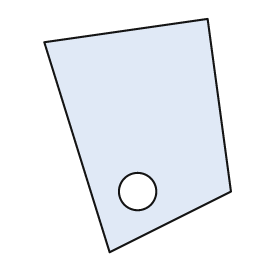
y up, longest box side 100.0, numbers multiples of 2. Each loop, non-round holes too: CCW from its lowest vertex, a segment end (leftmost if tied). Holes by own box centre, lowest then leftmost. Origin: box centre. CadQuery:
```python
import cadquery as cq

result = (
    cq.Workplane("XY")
    .moveTo(-12.0, -50.0)
    .lineTo(40.0, -24.0)
    .lineTo(30.0, 50.0)
    .lineTo(-40.0, 40.0)
    .close()
    .moveTo(0.0, -24.0)
    .circle(8.0)
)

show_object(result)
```